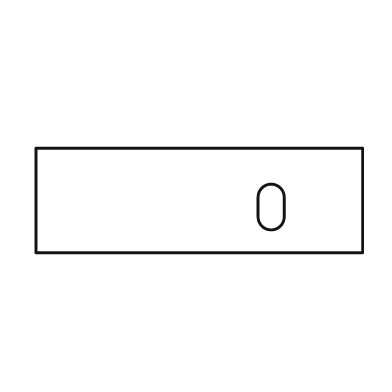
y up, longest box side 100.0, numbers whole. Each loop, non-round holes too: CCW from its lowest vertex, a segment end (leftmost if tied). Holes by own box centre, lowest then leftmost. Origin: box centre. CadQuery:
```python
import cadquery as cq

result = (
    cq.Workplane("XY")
    .moveTo(-50.0, -16.0)
    .lineTo(50.0, -16.0)
    .lineTo(50.0, 16.0)
    .lineTo(-50.0, 16.0)
    .close()
    .moveTo(18.0, -5.0)
    .threePointArc((22.0, -9.0), (26.0, -5.0))
    .lineTo(26.0, 1.0)
    .threePointArc((22.0, 5.0), (18.0, 1.0))
    .close()
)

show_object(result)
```